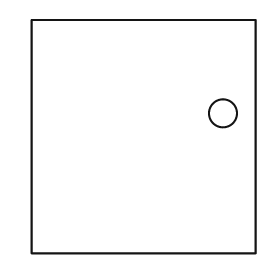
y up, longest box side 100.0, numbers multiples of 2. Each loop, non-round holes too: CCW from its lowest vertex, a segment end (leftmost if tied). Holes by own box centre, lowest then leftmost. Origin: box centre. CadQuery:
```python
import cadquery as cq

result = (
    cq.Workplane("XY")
    .moveTo(-48.0, -50.0)
    .lineTo(48.0, -50.0)
    .lineTo(48.0, 50.0)
    .lineTo(-48.0, 50.0)
    .close()
    .moveTo(34.0, 10.0)
    .circle(6.0)
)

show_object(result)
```